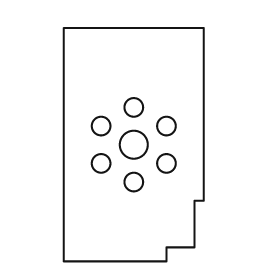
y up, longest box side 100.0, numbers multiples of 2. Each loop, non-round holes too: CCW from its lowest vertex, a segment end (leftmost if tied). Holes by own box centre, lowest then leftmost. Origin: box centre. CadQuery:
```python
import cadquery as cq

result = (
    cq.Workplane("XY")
    .moveTo(-30.0, -50.0)
    .lineTo(14.0, -50.0)
    .lineTo(14.0, -44.0)
    .lineTo(26.0, -44.0)
    .lineTo(26.0, -24.0)
    .lineTo(30.0, -24.0)
    .lineTo(30.0, 50.0)
    .lineTo(-30.0, 50.0)
    .close()
    .moveTo(0.0, -16.0)
    .circle(4.0)
    .moveTo(-14.0, -8.0)
    .circle(4.0)
    .moveTo(14.0, -8.0)
    .circle(4.0)
    .moveTo(0.0, 0.0)
    .circle(6.0)
    .moveTo(-14.0, 8.0)
    .circle(4.0)
    .moveTo(14.0, 8.0)
    .circle(4.0)
    .moveTo(0.0, 16.0)
    .circle(4.0)
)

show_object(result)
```